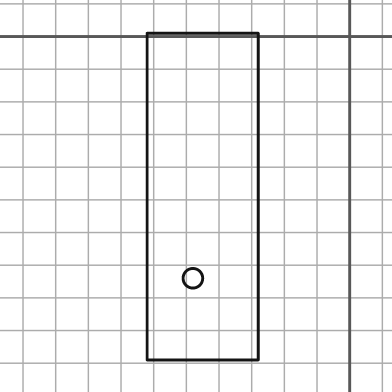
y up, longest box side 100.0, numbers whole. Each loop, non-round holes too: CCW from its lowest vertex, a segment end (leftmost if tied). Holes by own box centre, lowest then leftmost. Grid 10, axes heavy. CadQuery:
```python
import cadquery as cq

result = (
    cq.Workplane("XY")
    .moveTo(-62.0, -99.0)
    .lineTo(-28.0, -99.0)
    .lineTo(-28.0, 1.0)
    .lineTo(-62.0, 1.0)
    .close()
    .moveTo(-48.0, -74.0)
    .circle(3.0)
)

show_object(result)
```